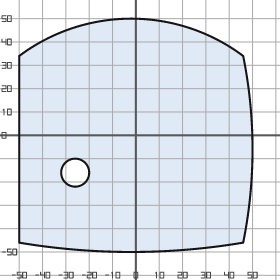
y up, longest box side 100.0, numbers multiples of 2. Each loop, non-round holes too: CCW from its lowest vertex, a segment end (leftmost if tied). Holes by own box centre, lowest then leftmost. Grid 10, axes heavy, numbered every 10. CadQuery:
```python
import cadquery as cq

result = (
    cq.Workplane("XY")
    .moveTo(-50.0, -46.0)
    .threePointArc((-2.0, -50.0), (46.0, -46.0))
    .threePointArc((50.0, -6.0), (46.0, 34.0))
    .threePointArc((-2.0, 50.0), (-50.0, 34.0))
    .close()
    .moveTo(-26.0, -16.0)
    .circle(6.0)
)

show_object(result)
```